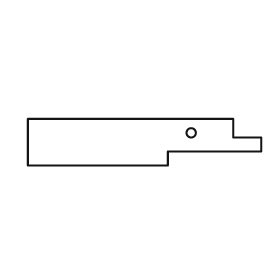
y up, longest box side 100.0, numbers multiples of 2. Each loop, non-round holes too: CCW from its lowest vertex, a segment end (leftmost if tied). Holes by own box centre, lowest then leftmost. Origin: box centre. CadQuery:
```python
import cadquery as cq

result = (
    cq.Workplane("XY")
    .moveTo(-50.0, -10.0)
    .lineTo(10.0, -10.0)
    .lineTo(10.0, -4.0)
    .lineTo(50.0, -4.0)
    .lineTo(50.0, 2.0)
    .lineTo(38.0, 2.0)
    .lineTo(38.0, 10.0)
    .lineTo(-50.0, 10.0)
    .close()
    .moveTo(20.0, 4.0)
    .circle(2.0)
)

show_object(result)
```